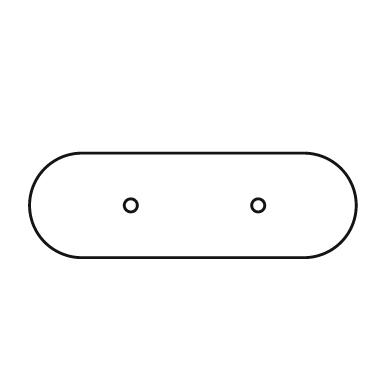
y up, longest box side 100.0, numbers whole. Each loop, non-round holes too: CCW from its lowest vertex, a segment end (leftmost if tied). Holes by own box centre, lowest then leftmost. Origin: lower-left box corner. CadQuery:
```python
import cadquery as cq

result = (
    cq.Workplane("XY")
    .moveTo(16.0, 0.0)
    .lineTo(84.0, 0.0)
    .threePointArc((100.0, 16.0), (84.0, 32.0))
    .lineTo(16.0, 32.0)
    .threePointArc((0.0, 16.0), (16.0, 0.0))
    .close()
    .moveTo(31.0, 16.0)
    .circle(2.0)
    .moveTo(70.0, 16.0)
    .circle(2.0)
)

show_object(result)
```